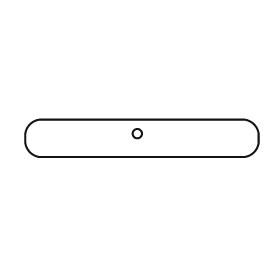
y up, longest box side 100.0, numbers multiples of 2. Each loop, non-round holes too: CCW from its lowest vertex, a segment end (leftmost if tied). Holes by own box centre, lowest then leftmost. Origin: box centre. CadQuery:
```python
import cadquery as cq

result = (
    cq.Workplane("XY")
    .moveTo(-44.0, -8.0)
    .lineTo(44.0, -8.0)
    .threePointArc((48.0, -6.0), (50.0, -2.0))
    .lineTo(50.0, 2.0)
    .threePointArc((48.0, 6.0), (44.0, 8.0))
    .lineTo(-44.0, 8.0)
    .threePointArc((-48.0, 6.0), (-50.0, 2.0))
    .lineTo(-50.0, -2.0)
    .threePointArc((-48.0, -6.0), (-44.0, -8.0))
    .close()
    .moveTo(-2.0, 2.0)
    .circle(2.0)
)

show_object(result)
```